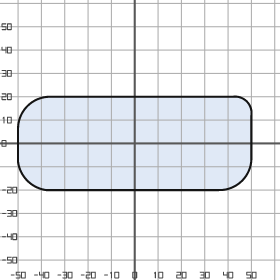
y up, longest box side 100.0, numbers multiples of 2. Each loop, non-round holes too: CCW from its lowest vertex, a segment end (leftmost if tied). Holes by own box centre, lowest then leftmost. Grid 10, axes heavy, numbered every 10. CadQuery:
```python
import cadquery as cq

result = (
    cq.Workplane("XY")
    .moveTo(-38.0, -20.0)
    .lineTo(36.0, -20.0)
    .threePointArc((46.0, -16.0), (50.0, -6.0))
    .lineTo(50.0, 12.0)
    .threePointArc((48.0, 18.0), (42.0, 20.0))
    .lineTo(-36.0, 20.0)
    .threePointArc((-46.0, 16.0), (-50.0, 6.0))
    .lineTo(-50.0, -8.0)
    .threePointArc((-46.0, -16.0), (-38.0, -20.0))
    .close()
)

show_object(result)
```